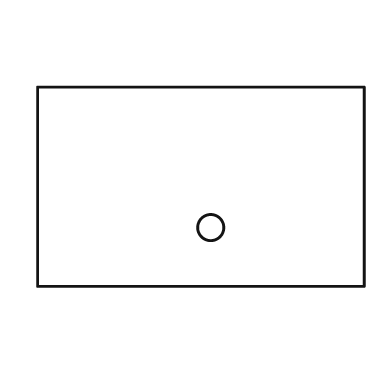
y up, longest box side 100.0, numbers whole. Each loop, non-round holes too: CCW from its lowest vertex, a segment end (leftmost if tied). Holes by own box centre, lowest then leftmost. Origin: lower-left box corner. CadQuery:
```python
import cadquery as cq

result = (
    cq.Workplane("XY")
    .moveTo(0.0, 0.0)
    .lineTo(100.0, 0.0)
    .lineTo(100.0, 61.0)
    .lineTo(0.0, 61.0)
    .close()
    .moveTo(53.0, 18.0)
    .circle(4.0)
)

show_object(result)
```